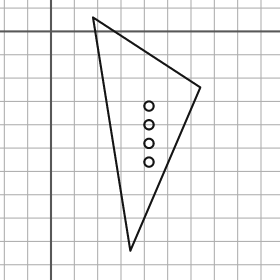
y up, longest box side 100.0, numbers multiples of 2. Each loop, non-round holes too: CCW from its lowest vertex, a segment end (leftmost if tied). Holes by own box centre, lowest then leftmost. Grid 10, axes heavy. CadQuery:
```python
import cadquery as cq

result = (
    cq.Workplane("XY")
    .moveTo(34.0, -94.0)
    .lineTo(64.0, -24.0)
    .lineTo(18.0, 6.0)
    .close()
    .moveTo(42.0, -56.0)
    .circle(2.0)
    .moveTo(42.0, -48.0)
    .circle(2.0)
    .moveTo(42.0, -40.0)
    .circle(2.0)
    .moveTo(42.0, -32.0)
    .circle(2.0)
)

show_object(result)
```